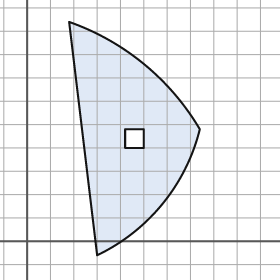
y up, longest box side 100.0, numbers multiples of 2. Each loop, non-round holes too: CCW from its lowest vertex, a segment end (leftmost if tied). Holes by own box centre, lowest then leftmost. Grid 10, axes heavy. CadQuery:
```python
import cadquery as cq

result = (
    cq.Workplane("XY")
    .moveTo(30.0, -6.0)
    .threePointArc((58.0, 16.0), (74.0, 48.0))
    .threePointArc((50.0, 76.0), (18.0, 94.0))
    .close()
    .moveTo(42.0, 40.0)
    .lineTo(50.0, 40.0)
    .lineTo(50.0, 48.0)
    .lineTo(42.0, 48.0)
    .close()
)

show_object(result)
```